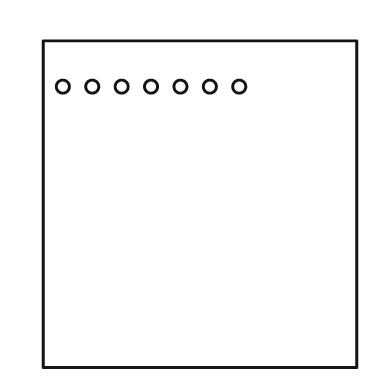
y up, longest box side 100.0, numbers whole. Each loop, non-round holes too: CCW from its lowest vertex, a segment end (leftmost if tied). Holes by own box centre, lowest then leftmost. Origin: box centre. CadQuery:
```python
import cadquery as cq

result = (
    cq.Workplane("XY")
    .moveTo(-48.0, -50.0)
    .lineTo(48.0, -50.0)
    .lineTo(48.0, 50.0)
    .lineTo(-48.0, 50.0)
    .close()
    .moveTo(-42.0, 36.0)
    .circle(2.0)
    .moveTo(-33.0, 36.0)
    .circle(2.0)
    .moveTo(-24.0, 36.0)
    .circle(2.0)
    .moveTo(-15.0, 36.0)
    .circle(2.0)
    .moveTo(-6.0, 36.0)
    .circle(2.0)
    .moveTo(3.0, 36.0)
    .circle(2.0)
    .moveTo(12.0, 36.0)
    .circle(2.0)
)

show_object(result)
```